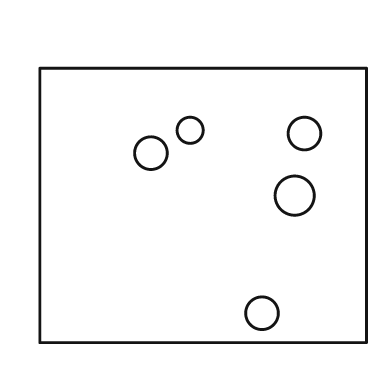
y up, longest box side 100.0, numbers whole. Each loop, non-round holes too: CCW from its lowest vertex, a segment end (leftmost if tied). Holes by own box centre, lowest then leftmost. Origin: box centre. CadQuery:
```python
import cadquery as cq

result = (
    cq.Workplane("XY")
    .moveTo(-50.0, -42.0)
    .lineTo(50.0, -42.0)
    .lineTo(50.0, 42.0)
    .lineTo(-50.0, 42.0)
    .close()
    .moveTo(18.0, -33.0)
    .circle(5.0)
    .moveTo(28.0, 3.0)
    .circle(6.0)
    .moveTo(-16.0, 16.0)
    .circle(5.0)
    .moveTo(31.0, 22.0)
    .circle(5.0)
    .moveTo(-4.0, 23.0)
    .circle(4.0)
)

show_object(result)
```